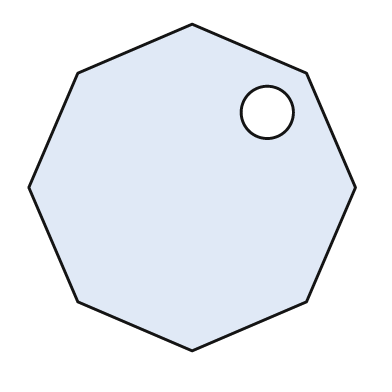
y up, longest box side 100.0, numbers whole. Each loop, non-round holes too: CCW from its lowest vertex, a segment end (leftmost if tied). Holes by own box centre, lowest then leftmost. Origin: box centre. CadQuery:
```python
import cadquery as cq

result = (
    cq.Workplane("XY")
    .moveTo(0.0, -50.0)
    .lineTo(35.0, -35.0)
    .lineTo(50.0, 0.0)
    .lineTo(35.0, 35.0)
    .lineTo(0.0, 50.0)
    .lineTo(-35.0, 35.0)
    .lineTo(-50.0, 0.0)
    .lineTo(-35.0, -35.0)
    .close()
    .moveTo(23.0, 23.0)
    .circle(8.0)
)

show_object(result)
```